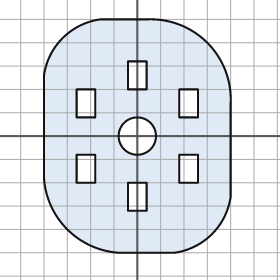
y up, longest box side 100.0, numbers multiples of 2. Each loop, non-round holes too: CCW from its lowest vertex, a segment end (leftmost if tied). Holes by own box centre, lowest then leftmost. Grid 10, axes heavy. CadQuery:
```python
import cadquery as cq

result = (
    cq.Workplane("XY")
    .moveTo(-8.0, -50.0)
    .lineTo(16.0, -50.0)
    .threePointArc((32.0, -42.0), (40.0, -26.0))
    .lineTo(40.0, 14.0)
    .threePointArc((30.0, 40.0), (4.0, 50.0))
    .lineTo(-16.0, 50.0)
    .threePointArc((-32.0, 42.0), (-40.0, 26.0))
    .lineTo(-40.0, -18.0)
    .threePointArc((-30.0, -40.0), (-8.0, -50.0))
    .close()
    .moveTo(-4.0, -32.0)
    .lineTo(4.0, -32.0)
    .lineTo(4.0, -20.0)
    .lineTo(-4.0, -20.0)
    .close()
    .moveTo(-26.0, -20.0)
    .lineTo(-18.0, -20.0)
    .lineTo(-18.0, -8.0)
    .lineTo(-26.0, -8.0)
    .close()
    .moveTo(18.0, -20.0)
    .lineTo(26.0, -20.0)
    .lineTo(26.0, -8.0)
    .lineTo(18.0, -8.0)
    .close()
    .moveTo(0.0, 0.0)
    .circle(8.0)
    .moveTo(-26.0, 8.0)
    .lineTo(-18.0, 8.0)
    .lineTo(-18.0, 20.0)
    .lineTo(-26.0, 20.0)
    .close()
    .moveTo(18.0, 8.0)
    .lineTo(26.0, 8.0)
    .lineTo(26.0, 20.0)
    .lineTo(18.0, 20.0)
    .close()
    .moveTo(-4.0, 20.0)
    .lineTo(4.0, 20.0)
    .lineTo(4.0, 32.0)
    .lineTo(-4.0, 32.0)
    .close()
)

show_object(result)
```